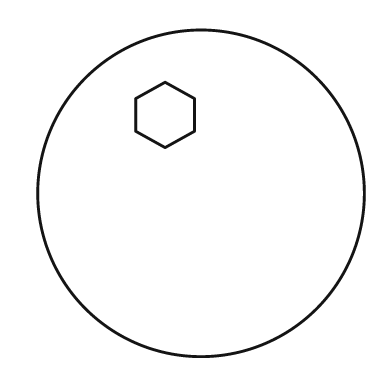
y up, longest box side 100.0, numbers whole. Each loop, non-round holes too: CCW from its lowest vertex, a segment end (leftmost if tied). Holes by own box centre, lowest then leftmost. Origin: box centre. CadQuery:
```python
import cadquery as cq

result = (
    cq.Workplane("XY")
    .moveTo(0.0, 0.0)
    .circle(50.0)
    .moveTo(-11.0, 14.0)
    .lineTo(-2.0, 19.0)
    .lineTo(-2.0, 29.0)
    .lineTo(-11.0, 34.0)
    .lineTo(-20.0, 29.0)
    .lineTo(-20.0, 19.0)
    .close()
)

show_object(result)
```